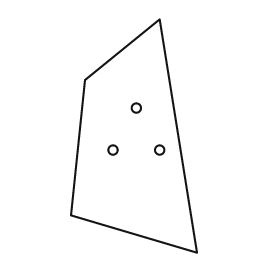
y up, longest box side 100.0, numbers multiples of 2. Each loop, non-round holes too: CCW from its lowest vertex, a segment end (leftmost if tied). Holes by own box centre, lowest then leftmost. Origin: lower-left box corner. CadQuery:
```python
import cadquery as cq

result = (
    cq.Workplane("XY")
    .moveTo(54.0, 0.0)
    .lineTo(38.0, 100.0)
    .lineTo(6.0, 74.0)
    .lineTo(0.0, 16.0)
    .close()
    .moveTo(18.0, 44.0)
    .circle(2.0)
    .moveTo(38.0, 44.0)
    .circle(2.0)
    .moveTo(28.0, 62.0)
    .circle(2.0)
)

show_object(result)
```